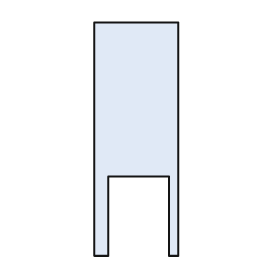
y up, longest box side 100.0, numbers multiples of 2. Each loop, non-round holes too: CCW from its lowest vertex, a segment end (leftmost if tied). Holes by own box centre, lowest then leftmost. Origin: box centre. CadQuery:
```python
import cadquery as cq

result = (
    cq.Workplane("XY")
    .moveTo(-18.0, -50.0)
    .lineTo(-12.0, -50.0)
    .lineTo(-12.0, -16.0)
    .lineTo(14.0, -16.0)
    .lineTo(14.0, -50.0)
    .lineTo(18.0, -50.0)
    .lineTo(18.0, 50.0)
    .lineTo(-18.0, 50.0)
    .close()
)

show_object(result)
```